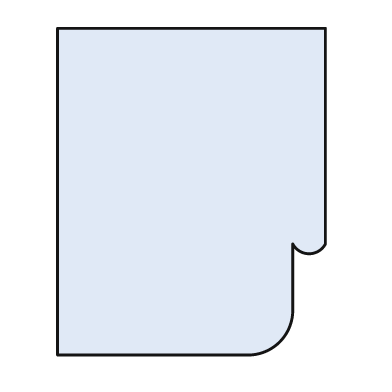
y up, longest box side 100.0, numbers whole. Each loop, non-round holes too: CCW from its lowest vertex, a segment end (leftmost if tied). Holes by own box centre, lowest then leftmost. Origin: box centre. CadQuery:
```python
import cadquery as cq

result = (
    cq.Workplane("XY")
    .moveTo(-41.0, -50.0)
    .lineTo(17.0, -50.0)
    .threePointArc((27.0, -46.0), (31.0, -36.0))
    .lineTo(31.0, -16.0)
    .threePointArc((36.0, -19.0), (41.0, -16.0))
    .lineTo(41.0, 50.0)
    .lineTo(-41.0, 50.0)
    .close()
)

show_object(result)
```